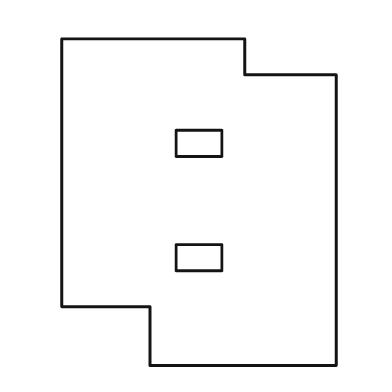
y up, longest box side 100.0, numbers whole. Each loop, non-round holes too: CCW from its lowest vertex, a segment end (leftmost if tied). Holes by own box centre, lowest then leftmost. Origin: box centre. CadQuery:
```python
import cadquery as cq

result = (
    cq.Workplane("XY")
    .moveTo(-15.0, -50.0)
    .lineTo(42.0, -50.0)
    .lineTo(42.0, 39.0)
    .lineTo(14.0, 39.0)
    .lineTo(14.0, 50.0)
    .lineTo(-42.0, 50.0)
    .lineTo(-42.0, -32.0)
    .lineTo(-15.0, -32.0)
    .close()
    .moveTo(-7.0, -21.0)
    .lineTo(7.0, -21.0)
    .lineTo(7.0, -13.0)
    .lineTo(-7.0, -13.0)
    .close()
    .moveTo(-7.0, 14.0)
    .lineTo(7.0, 14.0)
    .lineTo(7.0, 22.0)
    .lineTo(-7.0, 22.0)
    .close()
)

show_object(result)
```